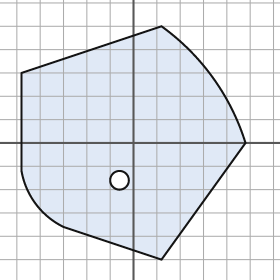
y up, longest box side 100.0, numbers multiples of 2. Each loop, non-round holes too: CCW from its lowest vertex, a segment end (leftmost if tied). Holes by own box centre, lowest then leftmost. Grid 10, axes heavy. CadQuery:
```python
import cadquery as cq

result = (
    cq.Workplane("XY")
    .moveTo(12.0, -50.0)
    .lineTo(48.0, 0.0)
    .threePointArc((34.0, 28.0), (12.0, 50.0))
    .lineTo(-48.0, 30.0)
    .lineTo(-48.0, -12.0)
    .threePointArc((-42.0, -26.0), (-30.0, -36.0))
    .close()
    .moveTo(-6.0, -16.0)
    .circle(4.0)
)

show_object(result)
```